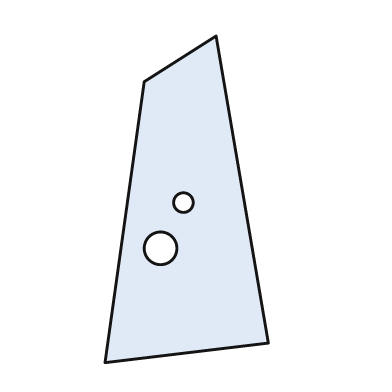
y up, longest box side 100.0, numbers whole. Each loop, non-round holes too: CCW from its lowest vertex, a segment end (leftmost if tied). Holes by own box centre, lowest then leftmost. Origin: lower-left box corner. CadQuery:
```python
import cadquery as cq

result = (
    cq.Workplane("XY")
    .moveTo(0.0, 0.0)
    .lineTo(50.0, 6.0)
    .lineTo(34.0, 100.0)
    .lineTo(12.0, 86.0)
    .close()
    .moveTo(17.0, 35.0)
    .circle(5.0)
    .moveTo(24.0, 49.0)
    .circle(3.0)
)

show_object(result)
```